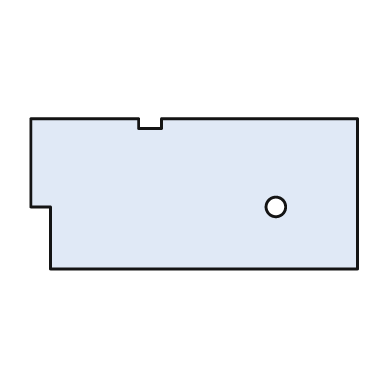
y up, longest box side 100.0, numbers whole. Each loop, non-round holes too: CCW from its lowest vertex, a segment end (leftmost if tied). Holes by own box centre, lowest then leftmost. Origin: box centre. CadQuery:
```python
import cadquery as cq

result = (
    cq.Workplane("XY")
    .moveTo(-44.0, -23.0)
    .lineTo(50.0, -23.0)
    .lineTo(50.0, 23.0)
    .lineTo(-10.0, 23.0)
    .lineTo(-10.0, 20.0)
    .lineTo(-17.0, 20.0)
    .lineTo(-17.0, 23.0)
    .lineTo(-50.0, 23.0)
    .lineTo(-50.0, -4.0)
    .lineTo(-44.0, -4.0)
    .close()
    .moveTo(25.0, -4.0)
    .circle(3.0)
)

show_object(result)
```